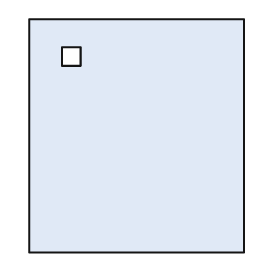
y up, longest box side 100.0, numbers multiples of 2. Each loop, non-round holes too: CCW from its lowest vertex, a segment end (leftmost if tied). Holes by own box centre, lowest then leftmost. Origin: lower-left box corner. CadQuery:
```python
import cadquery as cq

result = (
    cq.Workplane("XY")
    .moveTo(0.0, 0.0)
    .lineTo(92.0, 0.0)
    .lineTo(92.0, 100.0)
    .lineTo(0.0, 100.0)
    .close()
    .moveTo(14.0, 80.0)
    .lineTo(22.0, 80.0)
    .lineTo(22.0, 88.0)
    .lineTo(14.0, 88.0)
    .close()
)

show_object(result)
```